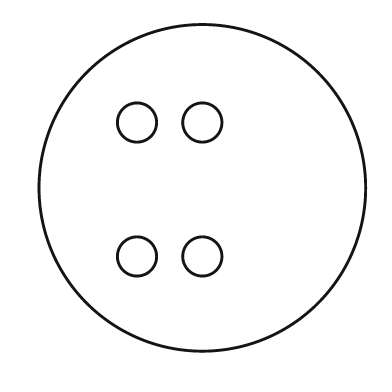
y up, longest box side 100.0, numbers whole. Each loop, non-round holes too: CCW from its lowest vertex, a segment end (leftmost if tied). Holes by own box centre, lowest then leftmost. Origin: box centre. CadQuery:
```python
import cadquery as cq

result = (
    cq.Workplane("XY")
    .moveTo(0.0, 0.0)
    .circle(50.0)
    .moveTo(-20.0, -21.0)
    .circle(6.0)
    .moveTo(0.0, -21.0)
    .circle(6.0)
    .moveTo(-20.0, 20.0)
    .circle(6.0)
    .moveTo(0.0, 20.0)
    .circle(6.0)
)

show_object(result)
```